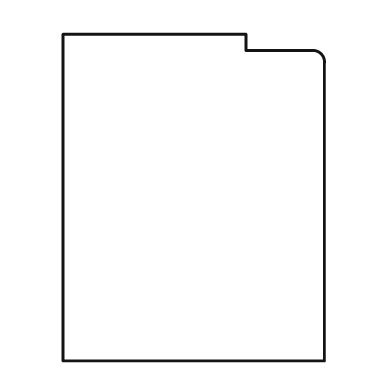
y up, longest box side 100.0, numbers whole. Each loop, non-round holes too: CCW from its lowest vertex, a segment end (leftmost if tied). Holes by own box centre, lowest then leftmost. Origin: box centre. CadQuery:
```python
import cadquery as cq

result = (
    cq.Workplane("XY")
    .moveTo(-40.0, -50.0)
    .lineTo(40.0, -50.0)
    .lineTo(40.0, 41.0)
    .threePointArc((39.0, 44.0), (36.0, 45.0))
    .lineTo(16.0, 45.0)
    .lineTo(16.0, 50.0)
    .lineTo(-40.0, 50.0)
    .close()
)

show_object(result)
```